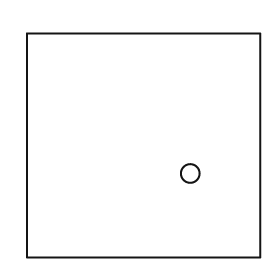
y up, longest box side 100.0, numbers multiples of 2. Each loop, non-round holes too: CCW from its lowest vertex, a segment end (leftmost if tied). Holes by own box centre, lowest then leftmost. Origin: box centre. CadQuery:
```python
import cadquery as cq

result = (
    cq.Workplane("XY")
    .moveTo(-50.0, -48.0)
    .lineTo(50.0, -48.0)
    .lineTo(50.0, 48.0)
    .lineTo(-50.0, 48.0)
    .close()
    .moveTo(20.0, -12.0)
    .circle(4.0)
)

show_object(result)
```